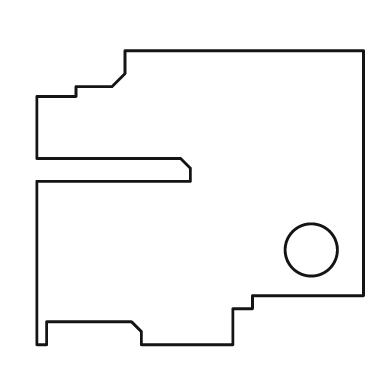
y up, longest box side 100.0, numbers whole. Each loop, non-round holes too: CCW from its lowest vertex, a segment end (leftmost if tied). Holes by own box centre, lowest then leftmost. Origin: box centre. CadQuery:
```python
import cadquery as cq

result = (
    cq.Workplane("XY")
    .moveTo(-50.0, -45.0)
    .lineTo(-47.0, -45.0)
    .lineTo(-47.0, -38.0)
    .lineTo(-21.0, -38.0)
    .lineTo(-18.0, -41.0)
    .lineTo(-18.0, -45.0)
    .lineTo(10.0, -45.0)
    .lineTo(10.0, -34.0)
    .lineTo(16.0, -34.0)
    .lineTo(16.0, -30.0)
    .lineTo(50.0, -30.0)
    .lineTo(50.0, 45.0)
    .lineTo(-23.0, 45.0)
    .lineTo(-23.0, 38.0)
    .lineTo(-27.0, 34.0)
    .lineTo(-38.0, 34.0)
    .lineTo(-38.0, 31.0)
    .lineTo(-50.0, 31.0)
    .lineTo(-50.0, 12.0)
    .lineTo(-6.0, 12.0)
    .lineTo(-3.0, 9.0)
    .lineTo(-3.0, 5.0)
    .lineTo(-50.0, 5.0)
    .close()
    .moveTo(34.0, -16.0)
    .circle(8.0)
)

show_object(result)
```